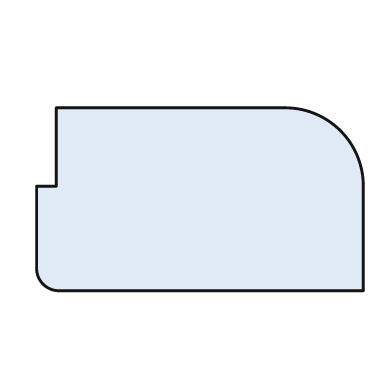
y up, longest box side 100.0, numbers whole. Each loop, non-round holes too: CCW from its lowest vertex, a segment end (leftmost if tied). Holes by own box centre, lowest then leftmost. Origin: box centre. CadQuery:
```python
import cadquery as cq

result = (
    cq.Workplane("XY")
    .moveTo(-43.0, -28.0)
    .lineTo(50.0, -28.0)
    .lineTo(50.0, 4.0)
    .threePointArc((43.0, 21.0), (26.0, 28.0))
    .lineTo(-44.0, 28.0)
    .lineTo(-44.0, 4.0)
    .lineTo(-50.0, 4.0)
    .lineTo(-50.0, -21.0)
    .threePointArc((-48.0, -26.0), (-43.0, -28.0))
    .close()
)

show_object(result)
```